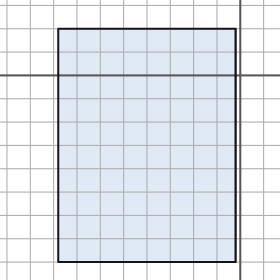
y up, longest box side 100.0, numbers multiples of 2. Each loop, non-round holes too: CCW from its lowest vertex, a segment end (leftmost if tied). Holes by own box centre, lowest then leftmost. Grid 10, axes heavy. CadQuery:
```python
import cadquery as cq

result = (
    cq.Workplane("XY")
    .moveTo(-78.0, -80.0)
    .lineTo(-2.0, -80.0)
    .lineTo(-2.0, 20.0)
    .lineTo(-78.0, 20.0)
    .close()
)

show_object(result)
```